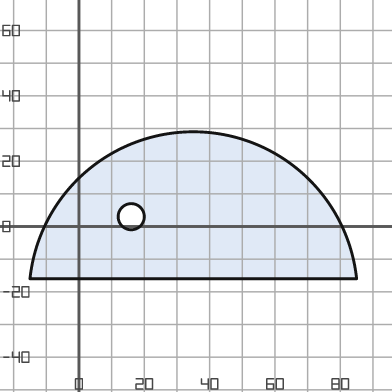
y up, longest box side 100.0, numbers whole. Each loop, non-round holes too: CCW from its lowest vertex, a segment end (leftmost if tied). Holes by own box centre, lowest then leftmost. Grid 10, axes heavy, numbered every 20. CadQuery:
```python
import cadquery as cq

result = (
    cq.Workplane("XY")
    .moveTo(-15.0, -16.0)
    .lineTo(85.0, -16.0)
    .threePointArc((35.0, 29.0), (-15.0, -16.0))
    .close()
    .moveTo(16.0, 3.0)
    .circle(4.0)
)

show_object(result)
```